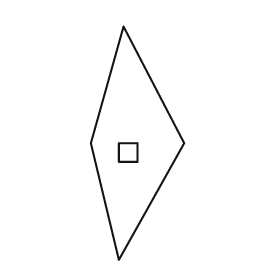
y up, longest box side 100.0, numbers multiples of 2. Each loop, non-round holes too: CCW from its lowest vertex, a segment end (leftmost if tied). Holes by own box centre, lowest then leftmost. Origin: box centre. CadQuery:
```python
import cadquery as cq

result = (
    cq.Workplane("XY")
    .moveTo(-8.0, -50.0)
    .lineTo(20.0, 0.0)
    .lineTo(-6.0, 50.0)
    .lineTo(-20.0, 0.0)
    .close()
    .moveTo(-8.0, -8.0)
    .lineTo(0.0, -8.0)
    .lineTo(0.0, 0.0)
    .lineTo(-8.0, 0.0)
    .close()
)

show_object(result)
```